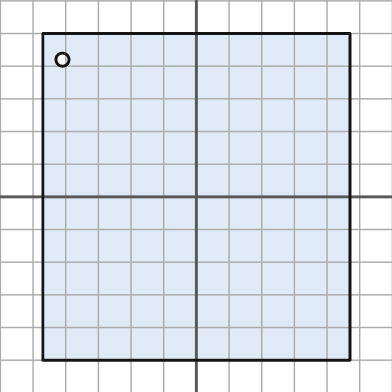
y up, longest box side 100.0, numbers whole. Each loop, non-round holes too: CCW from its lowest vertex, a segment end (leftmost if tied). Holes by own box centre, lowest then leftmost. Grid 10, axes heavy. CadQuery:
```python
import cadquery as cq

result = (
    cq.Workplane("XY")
    .moveTo(-47.0, -50.0)
    .lineTo(47.0, -50.0)
    .lineTo(47.0, 50.0)
    .lineTo(-47.0, 50.0)
    .close()
    .moveTo(-41.0, 42.0)
    .circle(2.0)
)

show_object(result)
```